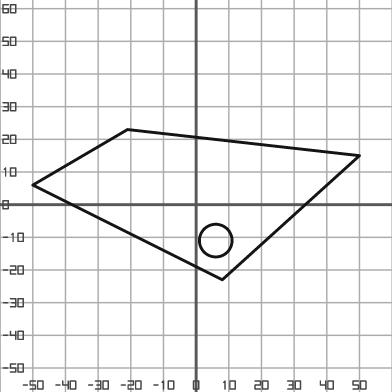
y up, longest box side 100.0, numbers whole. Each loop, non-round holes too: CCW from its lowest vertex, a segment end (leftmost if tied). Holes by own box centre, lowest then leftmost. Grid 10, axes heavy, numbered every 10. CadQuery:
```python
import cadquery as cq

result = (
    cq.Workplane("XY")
    .moveTo(8.0, -23.0)
    .lineTo(50.0, 15.0)
    .lineTo(-21.0, 23.0)
    .lineTo(-50.0, 6.0)
    .close()
    .moveTo(6.0, -11.0)
    .circle(5.0)
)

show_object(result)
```